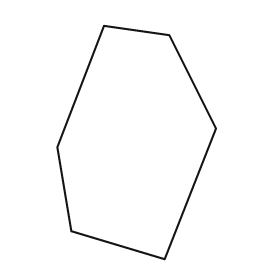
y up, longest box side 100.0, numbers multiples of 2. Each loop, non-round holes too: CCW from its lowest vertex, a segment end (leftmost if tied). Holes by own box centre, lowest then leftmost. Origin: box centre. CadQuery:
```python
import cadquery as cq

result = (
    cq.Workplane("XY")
    .moveTo(12.0, -50.0)
    .lineTo(34.0, 6.0)
    .lineTo(14.0, 46.0)
    .lineTo(-14.0, 50.0)
    .lineTo(-34.0, -2.0)
    .lineTo(-28.0, -38.0)
    .close()
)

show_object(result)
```